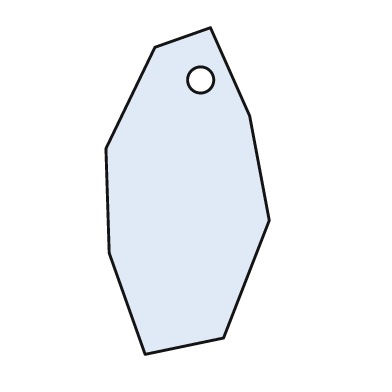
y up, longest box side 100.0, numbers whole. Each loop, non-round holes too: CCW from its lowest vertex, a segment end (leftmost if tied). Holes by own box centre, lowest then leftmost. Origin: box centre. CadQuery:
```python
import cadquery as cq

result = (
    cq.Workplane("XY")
    .moveTo(-13.0, -50.0)
    .lineTo(11.0, -45.0)
    .lineTo(25.0, -9.0)
    .lineTo(19.0, 23.0)
    .lineTo(7.0, 50.0)
    .lineTo(-10.0, 44.0)
    .lineTo(-25.0, 13.0)
    .lineTo(-24.0, -19.0)
    .close()
    .moveTo(4.0, 34.0)
    .circle(4.0)
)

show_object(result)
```